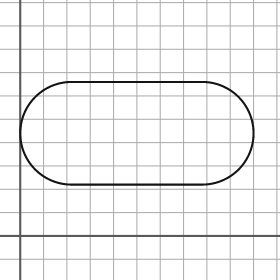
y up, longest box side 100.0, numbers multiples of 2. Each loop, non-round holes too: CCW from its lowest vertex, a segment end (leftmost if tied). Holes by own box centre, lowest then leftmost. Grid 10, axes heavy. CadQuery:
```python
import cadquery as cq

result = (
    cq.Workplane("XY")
    .moveTo(22.0, 22.0)
    .lineTo(78.0, 22.0)
    .threePointArc((100.0, 44.0), (78.0, 66.0))
    .lineTo(22.0, 66.0)
    .threePointArc((0.0, 44.0), (22.0, 22.0))
    .close()
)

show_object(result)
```